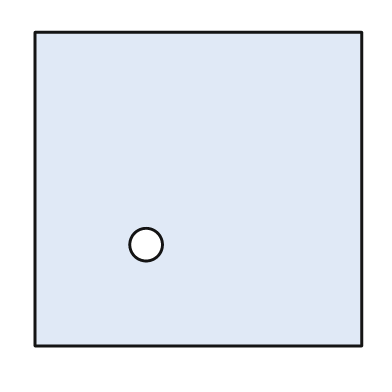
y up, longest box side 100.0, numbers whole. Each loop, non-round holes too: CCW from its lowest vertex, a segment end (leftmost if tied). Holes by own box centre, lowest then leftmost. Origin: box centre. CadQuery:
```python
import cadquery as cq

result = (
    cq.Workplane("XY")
    .moveTo(-50.0, -48.0)
    .lineTo(50.0, -48.0)
    .lineTo(50.0, 48.0)
    .lineTo(-50.0, 48.0)
    .close()
    .moveTo(-16.0, -17.0)
    .circle(5.0)
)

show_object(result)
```